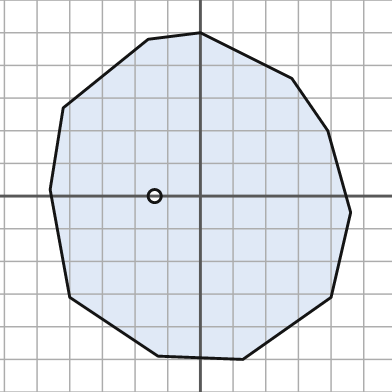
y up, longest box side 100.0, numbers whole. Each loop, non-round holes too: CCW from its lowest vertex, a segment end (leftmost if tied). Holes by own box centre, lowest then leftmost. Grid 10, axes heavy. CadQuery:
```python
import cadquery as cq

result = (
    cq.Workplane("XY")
    .moveTo(13.0, -50.0)
    .lineTo(40.0, -31.0)
    .lineTo(46.0, -5.0)
    .lineTo(39.0, 20.0)
    .lineTo(28.0, 36.0)
    .lineTo(0.0, 50.0)
    .lineTo(-16.0, 48.0)
    .lineTo(-42.0, 27.0)
    .lineTo(-46.0, 2.0)
    .lineTo(-40.0, -31.0)
    .lineTo(-13.0, -49.0)
    .close()
    .moveTo(-14.0, 0.0)
    .circle(2.0)
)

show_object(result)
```